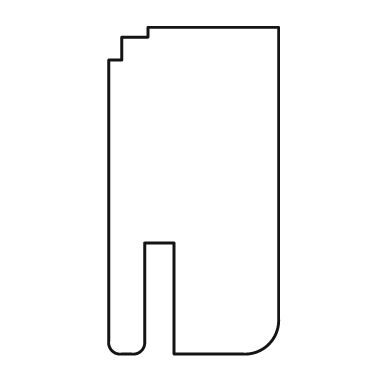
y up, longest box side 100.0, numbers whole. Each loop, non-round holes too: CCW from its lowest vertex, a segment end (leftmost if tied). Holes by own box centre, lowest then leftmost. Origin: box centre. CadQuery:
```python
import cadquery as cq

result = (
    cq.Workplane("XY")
    .moveTo(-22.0, -50.0)
    .lineTo(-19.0, -50.0)
    .threePointArc((-16.0, -49.0), (-15.0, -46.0))
    .lineTo(-15.0, -16.0)
    .lineTo(-6.0, -16.0)
    .lineTo(-6.0, -50.0)
    .lineTo(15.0, -50.0)
    .threePointArc((23.0, -47.0), (26.0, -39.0))
    .lineTo(26.0, 50.0)
    .lineTo(-14.0, 50.0)
    .lineTo(-14.0, 47.0)
    .lineTo(-22.0, 47.0)
    .lineTo(-22.0, 40.0)
    .lineTo(-26.0, 40.0)
    .lineTo(-26.0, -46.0)
    .threePointArc((-25.0, -49.0), (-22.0, -50.0))
    .close()
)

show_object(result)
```